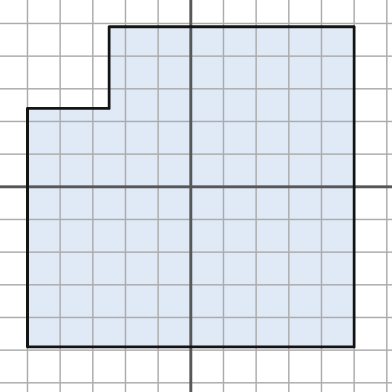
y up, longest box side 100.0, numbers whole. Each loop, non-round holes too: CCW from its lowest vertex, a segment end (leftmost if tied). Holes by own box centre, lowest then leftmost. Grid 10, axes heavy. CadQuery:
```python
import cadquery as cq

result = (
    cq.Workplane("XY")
    .moveTo(-50.0, -49.0)
    .lineTo(50.0, -49.0)
    .lineTo(50.0, 49.0)
    .lineTo(-25.0, 49.0)
    .lineTo(-25.0, 24.0)
    .lineTo(-50.0, 24.0)
    .close()
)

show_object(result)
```